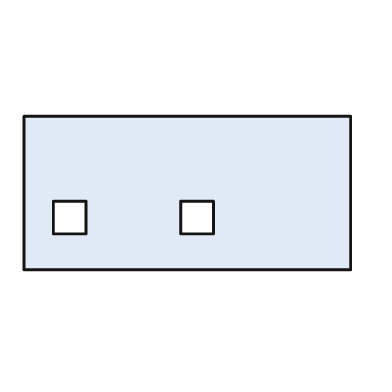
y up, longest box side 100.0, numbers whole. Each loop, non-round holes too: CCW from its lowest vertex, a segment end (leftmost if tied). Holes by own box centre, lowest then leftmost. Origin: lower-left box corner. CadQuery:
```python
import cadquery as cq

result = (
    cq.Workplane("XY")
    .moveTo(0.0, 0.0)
    .lineTo(100.0, 0.0)
    .lineTo(100.0, 47.0)
    .lineTo(0.0, 47.0)
    .close()
    .moveTo(9.0, 11.0)
    .lineTo(19.0, 11.0)
    .lineTo(19.0, 21.0)
    .lineTo(9.0, 21.0)
    .close()
    .moveTo(48.0, 11.0)
    .lineTo(58.0, 11.0)
    .lineTo(58.0, 21.0)
    .lineTo(48.0, 21.0)
    .close()
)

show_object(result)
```